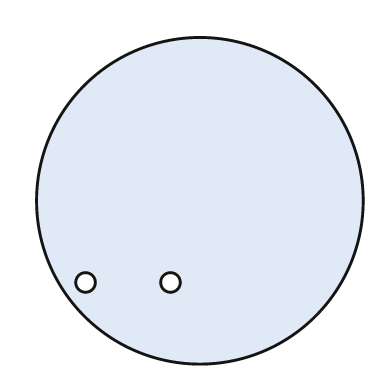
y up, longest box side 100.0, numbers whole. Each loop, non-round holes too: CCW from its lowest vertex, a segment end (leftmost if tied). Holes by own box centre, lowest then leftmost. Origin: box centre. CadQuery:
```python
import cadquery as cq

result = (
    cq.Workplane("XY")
    .moveTo(0.0, 0.0)
    .circle(50.0)
    .moveTo(-35.0, -25.0)
    .circle(3.0)
    .moveTo(-9.0, -25.0)
    .circle(3.0)
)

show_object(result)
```